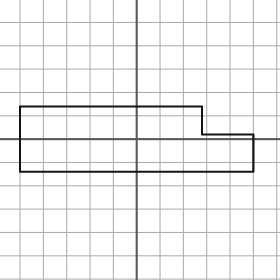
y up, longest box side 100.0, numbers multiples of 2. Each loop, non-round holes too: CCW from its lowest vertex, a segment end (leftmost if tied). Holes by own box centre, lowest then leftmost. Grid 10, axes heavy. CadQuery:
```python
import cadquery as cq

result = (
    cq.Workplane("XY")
    .moveTo(-50.0, -14.0)
    .lineTo(50.0, -14.0)
    .lineTo(50.0, 2.0)
    .lineTo(28.0, 2.0)
    .lineTo(28.0, 14.0)
    .lineTo(-50.0, 14.0)
    .close()
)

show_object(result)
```